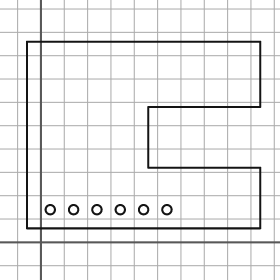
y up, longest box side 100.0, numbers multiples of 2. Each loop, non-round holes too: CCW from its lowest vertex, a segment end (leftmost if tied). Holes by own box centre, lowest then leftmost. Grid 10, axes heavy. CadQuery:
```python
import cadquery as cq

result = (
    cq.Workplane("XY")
    .moveTo(-6.0, 6.0)
    .lineTo(94.0, 6.0)
    .lineTo(94.0, 32.0)
    .lineTo(46.0, 32.0)
    .lineTo(46.0, 58.0)
    .lineTo(94.0, 58.0)
    .lineTo(94.0, 86.0)
    .lineTo(-6.0, 86.0)
    .close()
    .moveTo(4.0, 14.0)
    .circle(2.0)
    .moveTo(14.0, 14.0)
    .circle(2.0)
    .moveTo(24.0, 14.0)
    .circle(2.0)
    .moveTo(34.0, 14.0)
    .circle(2.0)
    .moveTo(44.0, 14.0)
    .circle(2.0)
    .moveTo(54.0, 14.0)
    .circle(2.0)
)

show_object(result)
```